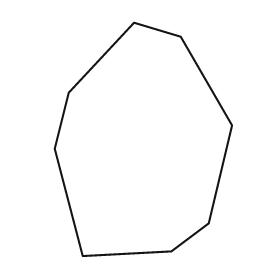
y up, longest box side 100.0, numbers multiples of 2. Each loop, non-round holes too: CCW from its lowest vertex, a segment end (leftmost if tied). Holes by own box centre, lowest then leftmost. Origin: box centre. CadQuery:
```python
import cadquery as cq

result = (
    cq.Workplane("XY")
    .moveTo(-26.0, -50.0)
    .lineTo(12.0, -48.0)
    .lineTo(28.0, -36.0)
    .lineTo(38.0, 6.0)
    .lineTo(16.0, 44.0)
    .lineTo(-4.0, 50.0)
    .lineTo(-32.0, 20.0)
    .lineTo(-38.0, -4.0)
    .close()
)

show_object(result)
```